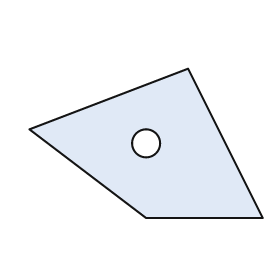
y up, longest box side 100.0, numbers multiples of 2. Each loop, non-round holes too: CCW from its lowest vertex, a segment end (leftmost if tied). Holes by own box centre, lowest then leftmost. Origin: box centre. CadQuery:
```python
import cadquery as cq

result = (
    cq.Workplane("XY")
    .moveTo(0.0, -32.0)
    .lineTo(50.0, -32.0)
    .lineTo(18.0, 32.0)
    .lineTo(-50.0, 6.0)
    .close()
    .moveTo(0.0, 0.0)
    .circle(6.0)
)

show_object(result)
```